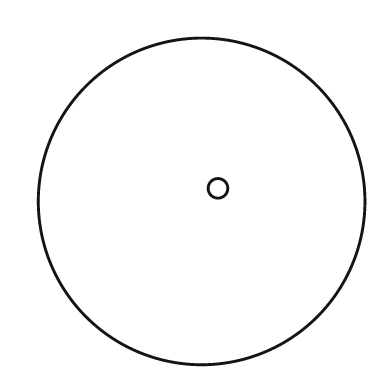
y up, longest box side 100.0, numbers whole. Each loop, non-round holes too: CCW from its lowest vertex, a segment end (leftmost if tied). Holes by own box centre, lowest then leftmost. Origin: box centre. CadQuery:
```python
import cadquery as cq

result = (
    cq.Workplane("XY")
    .moveTo(0.0, 0.0)
    .circle(50.0)
    .moveTo(5.0, 4.0)
    .circle(3.0)
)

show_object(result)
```